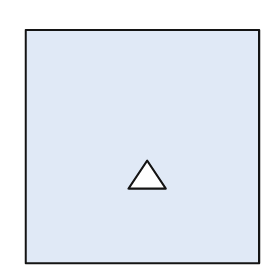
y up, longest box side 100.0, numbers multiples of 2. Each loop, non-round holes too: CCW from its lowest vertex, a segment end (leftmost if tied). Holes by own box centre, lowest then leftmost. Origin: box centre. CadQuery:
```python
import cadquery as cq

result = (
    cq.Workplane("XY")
    .moveTo(-50.0, -50.0)
    .lineTo(50.0, -50.0)
    .lineTo(50.0, 50.0)
    .lineTo(-50.0, 50.0)
    .close()
    .moveTo(-6.0, -18.0)
    .lineTo(10.0, -18.0)
    .lineTo(2.0, -6.0)
    .close()
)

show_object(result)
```